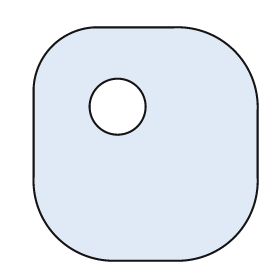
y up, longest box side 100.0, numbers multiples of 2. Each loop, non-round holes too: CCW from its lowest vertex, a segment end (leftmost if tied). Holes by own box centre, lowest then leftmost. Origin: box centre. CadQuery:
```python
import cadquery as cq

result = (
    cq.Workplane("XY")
    .moveTo(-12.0, -50.0)
    .lineTo(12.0, -50.0)
    .threePointArc((38.0, -40.0), (48.0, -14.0))
    .lineTo(48.0, 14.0)
    .threePointArc((38.0, 40.0), (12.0, 50.0))
    .lineTo(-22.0, 50.0)
    .threePointArc((-40.0, 42.0), (-48.0, 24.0))
    .lineTo(-48.0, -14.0)
    .threePointArc((-38.0, -40.0), (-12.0, -50.0))
    .close()
    .moveTo(-12.0, 16.0)
    .circle(12.0)
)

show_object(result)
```